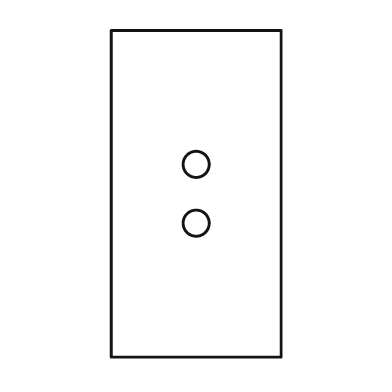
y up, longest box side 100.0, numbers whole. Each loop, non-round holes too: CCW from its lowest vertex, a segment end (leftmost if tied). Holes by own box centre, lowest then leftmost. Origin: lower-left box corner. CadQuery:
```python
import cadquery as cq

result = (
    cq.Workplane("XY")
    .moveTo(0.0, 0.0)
    .lineTo(52.0, 0.0)
    .lineTo(52.0, 100.0)
    .lineTo(0.0, 100.0)
    .close()
    .moveTo(26.0, 41.0)
    .circle(4.0)
    .moveTo(26.0, 59.0)
    .circle(4.0)
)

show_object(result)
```